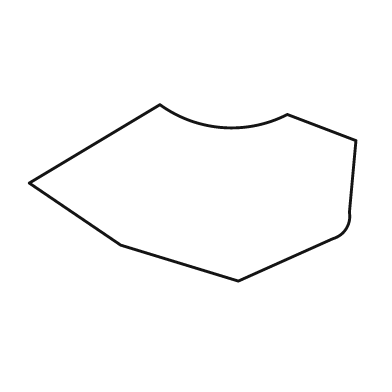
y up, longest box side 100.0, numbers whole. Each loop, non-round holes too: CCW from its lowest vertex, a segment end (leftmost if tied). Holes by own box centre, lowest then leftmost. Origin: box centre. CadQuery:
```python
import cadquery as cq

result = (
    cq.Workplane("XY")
    .moveTo(14.0, -27.0)
    .lineTo(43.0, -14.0)
    .threePointArc((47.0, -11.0), (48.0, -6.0))
    .lineTo(50.0, 16.0)
    .lineTo(29.0, 24.0)
    .threePointArc((9.0, 20.0), (-10.0, 27.0))
    .lineTo(-50.0, 3.0)
    .lineTo(-22.0, -16.0)
    .close()
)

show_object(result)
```